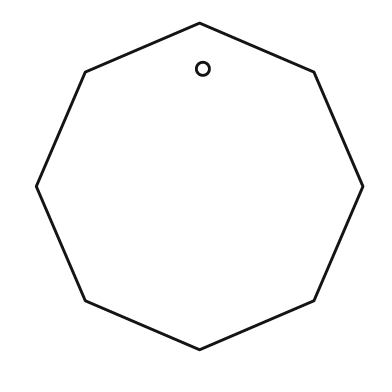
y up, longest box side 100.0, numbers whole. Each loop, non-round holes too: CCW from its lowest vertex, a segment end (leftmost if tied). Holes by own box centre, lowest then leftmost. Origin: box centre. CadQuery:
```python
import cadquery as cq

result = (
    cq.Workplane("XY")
    .moveTo(0.0, -50.0)
    .lineTo(35.0, -35.0)
    .lineTo(50.0, 0.0)
    .lineTo(35.0, 35.0)
    .lineTo(0.0, 50.0)
    .lineTo(-35.0, 35.0)
    .lineTo(-50.0, 0.0)
    .lineTo(-35.0, -35.0)
    .close()
    .moveTo(1.0, 36.0)
    .circle(2.0)
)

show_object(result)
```